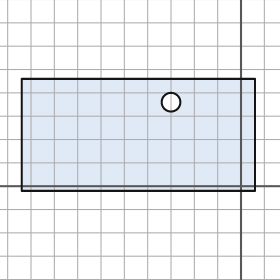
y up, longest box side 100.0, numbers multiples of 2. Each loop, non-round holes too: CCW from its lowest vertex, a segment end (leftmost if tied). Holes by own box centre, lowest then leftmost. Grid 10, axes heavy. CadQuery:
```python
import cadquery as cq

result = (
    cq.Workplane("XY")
    .moveTo(-94.0, -2.0)
    .lineTo(6.0, -2.0)
    .lineTo(6.0, 46.0)
    .lineTo(-94.0, 46.0)
    .close()
    .moveTo(-30.0, 36.0)
    .circle(4.0)
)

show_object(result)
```